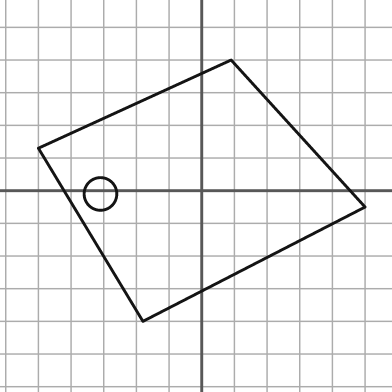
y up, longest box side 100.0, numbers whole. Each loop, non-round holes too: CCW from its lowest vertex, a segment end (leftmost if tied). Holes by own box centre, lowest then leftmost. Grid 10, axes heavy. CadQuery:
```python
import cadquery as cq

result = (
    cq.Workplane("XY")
    .moveTo(-18.0, -40.0)
    .lineTo(50.0, -5.0)
    .lineTo(9.0, 40.0)
    .lineTo(-50.0, 13.0)
    .close()
    .moveTo(-31.0, -1.0)
    .circle(5.0)
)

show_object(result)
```